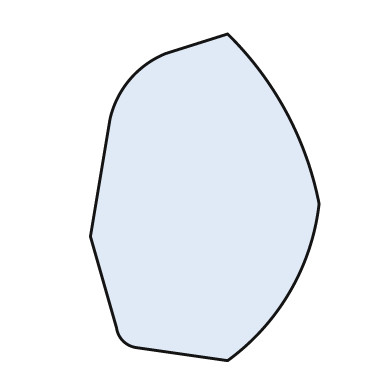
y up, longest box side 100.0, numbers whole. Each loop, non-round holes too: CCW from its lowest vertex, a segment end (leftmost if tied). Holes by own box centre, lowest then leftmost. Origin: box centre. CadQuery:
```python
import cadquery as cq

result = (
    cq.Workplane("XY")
    .moveTo(7.0, -50.0)
    .threePointArc((26.0, -29.0), (35.0, -2.0))
    .threePointArc((25.0, 26.0), (7.0, 50.0))
    .lineTo(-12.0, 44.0)
    .threePointArc((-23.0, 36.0), (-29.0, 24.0))
    .lineTo(-35.0, -12.0)
    .lineTo(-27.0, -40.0)
    .threePointArc((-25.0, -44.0), (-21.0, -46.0))
    .close()
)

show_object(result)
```